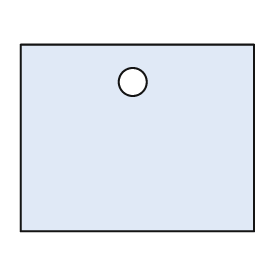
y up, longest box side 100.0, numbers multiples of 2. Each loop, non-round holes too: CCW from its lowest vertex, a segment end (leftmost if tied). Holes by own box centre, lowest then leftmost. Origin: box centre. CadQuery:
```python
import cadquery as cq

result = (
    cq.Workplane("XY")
    .moveTo(-50.0, -40.0)
    .lineTo(50.0, -40.0)
    .lineTo(50.0, 40.0)
    .lineTo(-50.0, 40.0)
    .close()
    .moveTo(-2.0, 24.0)
    .circle(6.0)
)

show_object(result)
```